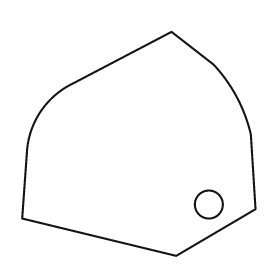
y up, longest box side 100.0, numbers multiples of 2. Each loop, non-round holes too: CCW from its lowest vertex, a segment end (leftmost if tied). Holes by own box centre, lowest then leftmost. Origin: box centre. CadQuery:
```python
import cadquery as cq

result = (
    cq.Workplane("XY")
    .moveTo(16.0, -48.0)
    .lineTo(50.0, -28.0)
    .lineTo(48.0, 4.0)
    .threePointArc((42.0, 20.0), (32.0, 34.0))
    .lineTo(14.0, 48.0)
    .lineTo(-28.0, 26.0)
    .threePointArc((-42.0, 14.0), (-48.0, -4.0))
    .lineTo(-50.0, -32.0)
    .close()
    .moveTo(30.0, -26.0)
    .circle(6.0)
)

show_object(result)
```